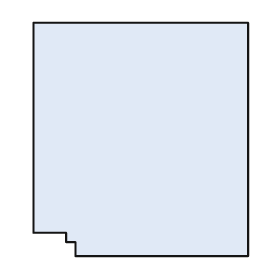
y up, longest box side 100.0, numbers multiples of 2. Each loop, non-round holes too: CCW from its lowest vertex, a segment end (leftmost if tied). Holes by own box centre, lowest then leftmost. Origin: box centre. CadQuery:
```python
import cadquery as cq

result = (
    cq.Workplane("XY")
    .moveTo(-28.0, -50.0)
    .lineTo(46.0, -50.0)
    .lineTo(46.0, 50.0)
    .lineTo(-46.0, 50.0)
    .lineTo(-46.0, -40.0)
    .lineTo(-32.0, -40.0)
    .lineTo(-32.0, -44.0)
    .lineTo(-28.0, -44.0)
    .close()
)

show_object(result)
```